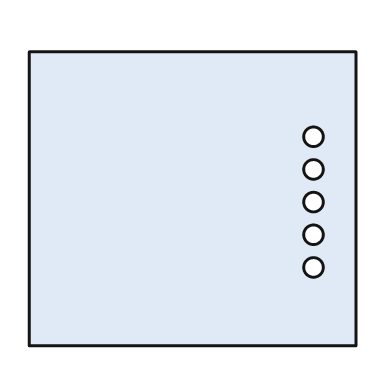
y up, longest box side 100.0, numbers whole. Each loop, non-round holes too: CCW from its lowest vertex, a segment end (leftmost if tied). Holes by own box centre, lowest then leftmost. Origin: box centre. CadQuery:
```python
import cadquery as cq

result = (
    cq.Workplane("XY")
    .moveTo(-50.0, -45.0)
    .lineTo(50.0, -45.0)
    .lineTo(50.0, 45.0)
    .lineTo(-50.0, 45.0)
    .close()
    .moveTo(37.0, -21.0)
    .circle(3.0)
    .moveTo(37.0, -11.0)
    .circle(3.0)
    .moveTo(37.0, -1.0)
    .circle(3.0)
    .moveTo(37.0, 9.0)
    .circle(3.0)
    .moveTo(37.0, 19.0)
    .circle(3.0)
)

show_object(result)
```